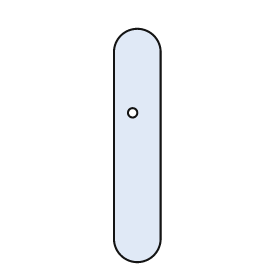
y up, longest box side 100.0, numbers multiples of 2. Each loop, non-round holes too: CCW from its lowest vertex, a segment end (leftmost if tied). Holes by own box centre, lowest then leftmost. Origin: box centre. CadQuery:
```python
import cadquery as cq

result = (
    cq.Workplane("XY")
    .moveTo(-10.0, -40.0)
    .threePointArc((0.0, -50.0), (10.0, -40.0))
    .lineTo(10.0, 40.0)
    .threePointArc((0.0, 50.0), (-10.0, 40.0))
    .close()
    .moveTo(-2.0, 14.0)
    .circle(2.0)
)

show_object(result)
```